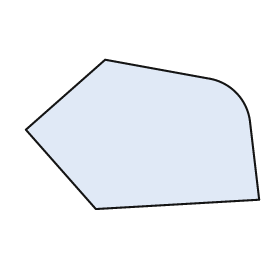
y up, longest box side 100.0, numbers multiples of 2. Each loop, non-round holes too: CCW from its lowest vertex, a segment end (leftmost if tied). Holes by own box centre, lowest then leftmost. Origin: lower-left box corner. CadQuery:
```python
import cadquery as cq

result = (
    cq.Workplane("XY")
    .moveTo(30.0, 0.0)
    .lineTo(100.0, 4.0)
    .lineTo(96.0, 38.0)
    .threePointArc((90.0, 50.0), (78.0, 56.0))
    .lineTo(34.0, 64.0)
    .lineTo(0.0, 34.0)
    .close()
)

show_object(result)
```